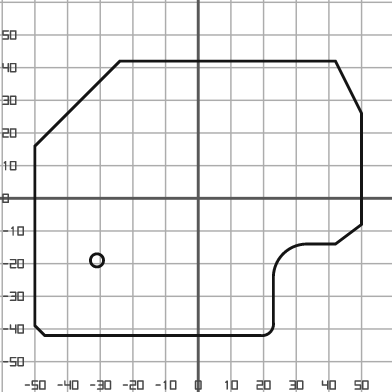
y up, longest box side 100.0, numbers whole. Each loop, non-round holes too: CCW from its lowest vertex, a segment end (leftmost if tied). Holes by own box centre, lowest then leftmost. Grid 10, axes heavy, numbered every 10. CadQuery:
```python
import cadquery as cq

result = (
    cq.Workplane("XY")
    .moveTo(-47.0, -42.0)
    .lineTo(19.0, -42.0)
    .threePointArc((22.0, -41.0), (23.0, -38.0))
    .lineTo(23.0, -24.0)
    .threePointArc((26.0, -17.0), (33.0, -14.0))
    .lineTo(42.0, -14.0)
    .lineTo(50.0, -8.0)
    .lineTo(50.0, 26.0)
    .lineTo(42.0, 42.0)
    .lineTo(-24.0, 42.0)
    .lineTo(-50.0, 16.0)
    .lineTo(-50.0, -39.0)
    .close()
    .moveTo(-31.0, -19.0)
    .circle(2.0)
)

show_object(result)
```